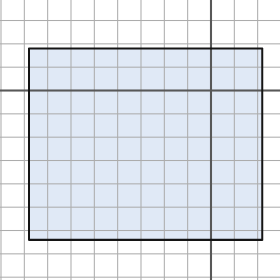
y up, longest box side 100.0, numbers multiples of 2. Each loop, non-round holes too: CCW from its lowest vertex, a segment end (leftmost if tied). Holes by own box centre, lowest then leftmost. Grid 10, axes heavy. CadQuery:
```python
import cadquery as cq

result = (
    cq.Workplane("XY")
    .moveTo(-78.0, -64.0)
    .lineTo(22.0, -64.0)
    .lineTo(22.0, 18.0)
    .lineTo(-78.0, 18.0)
    .close()
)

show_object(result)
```